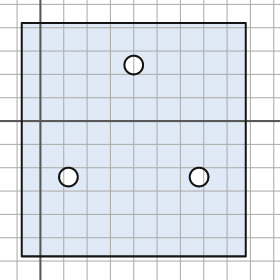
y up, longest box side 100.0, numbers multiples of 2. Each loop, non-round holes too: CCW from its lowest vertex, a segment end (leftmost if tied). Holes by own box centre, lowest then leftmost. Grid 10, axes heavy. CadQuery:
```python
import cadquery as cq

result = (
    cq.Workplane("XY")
    .moveTo(-8.0, -58.0)
    .lineTo(88.0, -58.0)
    .lineTo(88.0, 42.0)
    .lineTo(-8.0, 42.0)
    .close()
    .moveTo(12.0, -24.0)
    .circle(4.0)
    .moveTo(68.0, -24.0)
    .circle(4.0)
    .moveTo(40.0, 24.0)
    .circle(4.0)
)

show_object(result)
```